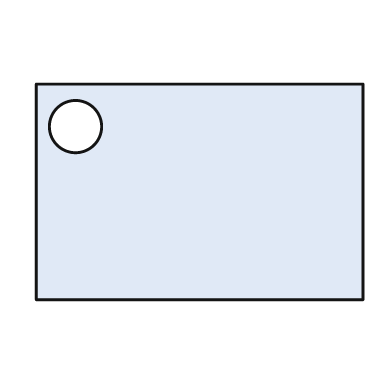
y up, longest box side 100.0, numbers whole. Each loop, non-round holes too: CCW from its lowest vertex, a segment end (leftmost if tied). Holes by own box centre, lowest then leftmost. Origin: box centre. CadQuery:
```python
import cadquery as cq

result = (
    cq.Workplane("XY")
    .moveTo(-50.0, -33.0)
    .lineTo(50.0, -33.0)
    .lineTo(50.0, 33.0)
    .lineTo(-50.0, 33.0)
    .close()
    .moveTo(-38.0, 20.0)
    .circle(8.0)
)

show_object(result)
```